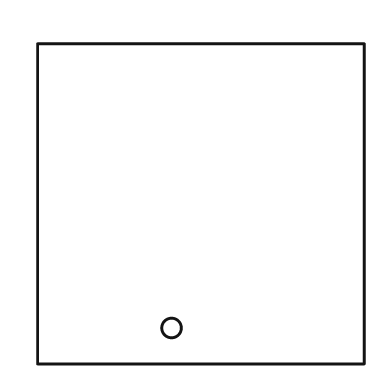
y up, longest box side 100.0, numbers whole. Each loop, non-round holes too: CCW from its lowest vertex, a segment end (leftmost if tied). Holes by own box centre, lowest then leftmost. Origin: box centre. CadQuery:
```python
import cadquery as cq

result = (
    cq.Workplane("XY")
    .moveTo(-50.0, -49.0)
    .lineTo(50.0, -49.0)
    .lineTo(50.0, 49.0)
    .lineTo(-50.0, 49.0)
    .close()
    .moveTo(-9.0, -38.0)
    .circle(3.0)
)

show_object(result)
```